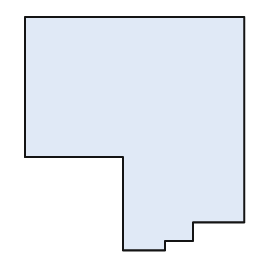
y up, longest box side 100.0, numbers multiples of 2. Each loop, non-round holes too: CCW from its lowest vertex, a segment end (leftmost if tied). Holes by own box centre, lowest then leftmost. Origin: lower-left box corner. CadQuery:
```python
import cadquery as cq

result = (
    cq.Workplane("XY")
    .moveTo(42.0, 0.0)
    .lineTo(60.0, 0.0)
    .lineTo(60.0, 4.0)
    .lineTo(72.0, 4.0)
    .lineTo(72.0, 12.0)
    .lineTo(94.0, 12.0)
    .lineTo(94.0, 100.0)
    .lineTo(0.0, 100.0)
    .lineTo(0.0, 40.0)
    .lineTo(42.0, 40.0)
    .close()
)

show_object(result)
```